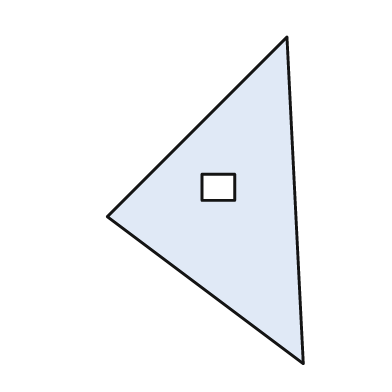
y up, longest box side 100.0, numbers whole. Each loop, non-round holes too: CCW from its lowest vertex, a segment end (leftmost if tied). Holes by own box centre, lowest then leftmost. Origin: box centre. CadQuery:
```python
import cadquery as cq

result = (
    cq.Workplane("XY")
    .moveTo(30.0, -50.0)
    .lineTo(25.0, 50.0)
    .lineTo(-30.0, -5.0)
    .close()
    .moveTo(-1.0, 0.0)
    .lineTo(9.0, 0.0)
    .lineTo(9.0, 8.0)
    .lineTo(-1.0, 8.0)
    .close()
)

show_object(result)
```